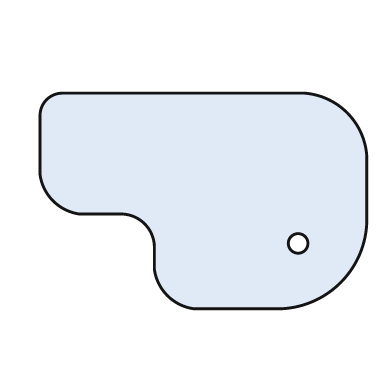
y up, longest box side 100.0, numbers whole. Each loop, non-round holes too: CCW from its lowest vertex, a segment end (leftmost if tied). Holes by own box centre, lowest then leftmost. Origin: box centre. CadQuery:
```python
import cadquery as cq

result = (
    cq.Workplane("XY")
    .moveTo(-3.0, -33.0)
    .lineTo(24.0, -33.0)
    .threePointArc((42.0, -25.0), (50.0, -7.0))
    .lineTo(50.0, 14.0)
    .threePointArc((44.0, 27.0), (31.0, 33.0))
    .lineTo(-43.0, 33.0)
    .threePointArc((-48.0, 31.0), (-50.0, 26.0))
    .lineTo(-50.0, 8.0)
    .threePointArc((-46.0, 0.0), (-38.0, -4.0))
    .lineTo(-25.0, -4.0)
    .threePointArc((-18.0, -7.0), (-15.0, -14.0))
    .lineTo(-15.0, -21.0)
    .threePointArc((-11.0, -29.0), (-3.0, -33.0))
    .close()
    .moveTo(29.0, -13.0)
    .circle(3.0)
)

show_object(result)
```